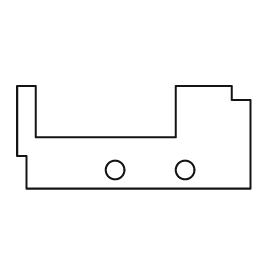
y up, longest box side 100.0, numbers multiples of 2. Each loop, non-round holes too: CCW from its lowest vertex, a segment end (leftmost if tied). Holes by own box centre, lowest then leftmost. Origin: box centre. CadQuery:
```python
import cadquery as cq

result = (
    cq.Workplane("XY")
    .moveTo(-46.0, -22.0)
    .lineTo(50.0, -22.0)
    .lineTo(50.0, 16.0)
    .lineTo(42.0, 16.0)
    .lineTo(42.0, 22.0)
    .lineTo(18.0, 22.0)
    .lineTo(18.0, 0.0)
    .lineTo(-42.0, 0.0)
    .lineTo(-42.0, 22.0)
    .lineTo(-50.0, 22.0)
    .lineTo(-50.0, -8.0)
    .lineTo(-46.0, -8.0)
    .close()
    .moveTo(-8.0, -14.0)
    .circle(4.0)
    .moveTo(22.0, -14.0)
    .circle(4.0)
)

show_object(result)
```